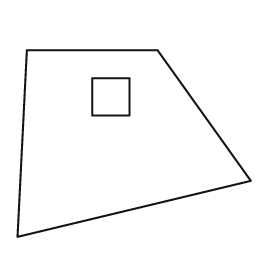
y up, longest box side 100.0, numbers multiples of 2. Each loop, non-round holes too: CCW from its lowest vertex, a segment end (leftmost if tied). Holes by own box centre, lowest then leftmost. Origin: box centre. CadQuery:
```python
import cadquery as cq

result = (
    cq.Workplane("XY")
    .moveTo(-50.0, -40.0)
    .lineTo(50.0, -16.0)
    .lineTo(10.0, 40.0)
    .lineTo(-46.0, 40.0)
    .close()
    .moveTo(-18.0, 12.0)
    .lineTo(-2.0, 12.0)
    .lineTo(-2.0, 28.0)
    .lineTo(-18.0, 28.0)
    .close()
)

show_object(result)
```